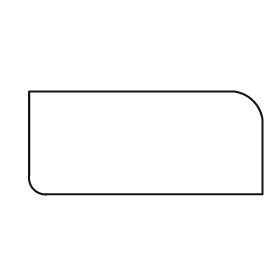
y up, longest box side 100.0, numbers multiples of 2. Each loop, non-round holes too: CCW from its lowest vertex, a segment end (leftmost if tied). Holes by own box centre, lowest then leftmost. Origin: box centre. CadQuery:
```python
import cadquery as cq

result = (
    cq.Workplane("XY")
    .moveTo(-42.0, -22.0)
    .lineTo(50.0, -22.0)
    .lineTo(50.0, 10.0)
    .threePointArc((46.0, 18.0), (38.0, 22.0))
    .lineTo(-50.0, 22.0)
    .lineTo(-50.0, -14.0)
    .threePointArc((-48.0, -20.0), (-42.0, -22.0))
    .close()
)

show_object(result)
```